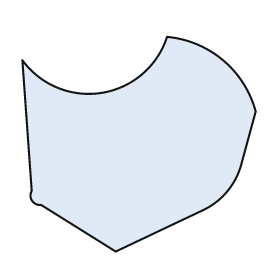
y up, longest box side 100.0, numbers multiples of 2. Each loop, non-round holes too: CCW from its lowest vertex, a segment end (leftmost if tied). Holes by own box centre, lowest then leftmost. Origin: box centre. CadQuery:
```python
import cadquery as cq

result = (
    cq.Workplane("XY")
    .moveTo(-10.0, -46.0)
    .lineTo(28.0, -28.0)
    .threePointArc((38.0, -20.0), (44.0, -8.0))
    .lineTo(50.0, 14.0)
    .threePointArc((36.0, 36.0), (12.0, 46.0))
    .threePointArc((-16.0, 22.0), (-50.0, 36.0))
    .lineTo(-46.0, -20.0)
    .threePointArc((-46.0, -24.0), (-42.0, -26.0))
    .close()
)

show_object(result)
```